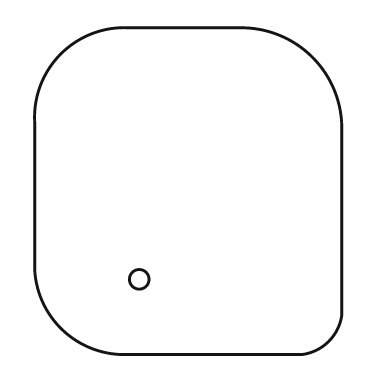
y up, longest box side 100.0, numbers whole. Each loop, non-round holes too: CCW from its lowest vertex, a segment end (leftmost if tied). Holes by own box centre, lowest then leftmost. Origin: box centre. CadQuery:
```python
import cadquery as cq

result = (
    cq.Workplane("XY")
    .moveTo(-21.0, -50.0)
    .lineTo(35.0, -50.0)
    .threePointArc((43.0, -46.0), (47.0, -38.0))
    .lineTo(47.0, 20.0)
    .threePointArc((38.0, 41.0), (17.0, 50.0))
    .lineTo(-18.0, 50.0)
    .threePointArc((-39.0, 42.0), (-47.0, 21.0))
    .lineTo(-47.0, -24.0)
    .threePointArc((-39.0, -42.0), (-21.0, -50.0))
    .close()
    .moveTo(-15.0, -27.0)
    .circle(3.0)
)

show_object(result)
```